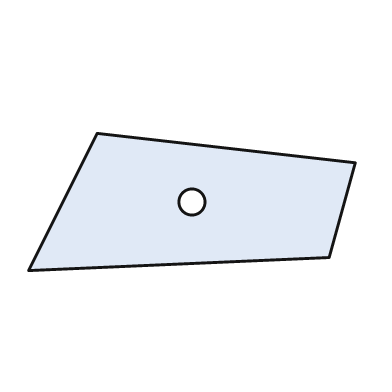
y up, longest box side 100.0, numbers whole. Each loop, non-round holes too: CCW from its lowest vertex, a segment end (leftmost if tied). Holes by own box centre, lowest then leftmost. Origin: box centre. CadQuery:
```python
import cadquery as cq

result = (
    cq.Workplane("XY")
    .moveTo(-50.0, -21.0)
    .lineTo(42.0, -17.0)
    .lineTo(50.0, 12.0)
    .lineTo(-29.0, 21.0)
    .close()
    .moveTo(0.0, 0.0)
    .circle(4.0)
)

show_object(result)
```